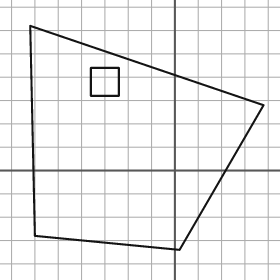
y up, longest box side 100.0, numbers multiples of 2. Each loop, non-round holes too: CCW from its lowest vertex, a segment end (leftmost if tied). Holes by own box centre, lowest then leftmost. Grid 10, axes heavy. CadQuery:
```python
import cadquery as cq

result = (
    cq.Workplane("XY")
    .moveTo(2.0, -34.0)
    .lineTo(38.0, 28.0)
    .lineTo(-62.0, 62.0)
    .lineTo(-60.0, -28.0)
    .close()
    .moveTo(-36.0, 32.0)
    .lineTo(-24.0, 32.0)
    .lineTo(-24.0, 44.0)
    .lineTo(-36.0, 44.0)
    .close()
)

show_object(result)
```